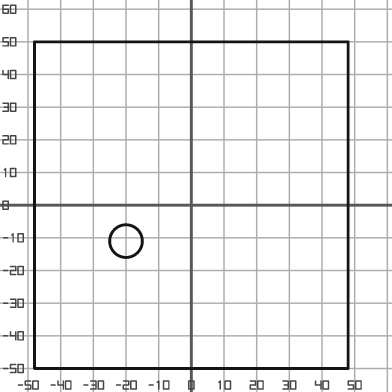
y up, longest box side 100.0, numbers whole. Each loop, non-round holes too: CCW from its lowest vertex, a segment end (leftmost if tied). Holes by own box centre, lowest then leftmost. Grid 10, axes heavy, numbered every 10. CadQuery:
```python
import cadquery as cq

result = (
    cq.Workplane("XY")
    .moveTo(-48.0, -50.0)
    .lineTo(48.0, -50.0)
    .lineTo(48.0, 50.0)
    .lineTo(-48.0, 50.0)
    .close()
    .moveTo(-20.0, -11.0)
    .circle(5.0)
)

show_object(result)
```